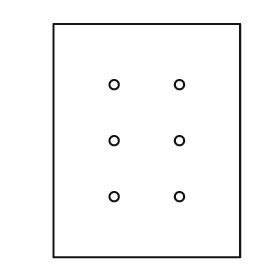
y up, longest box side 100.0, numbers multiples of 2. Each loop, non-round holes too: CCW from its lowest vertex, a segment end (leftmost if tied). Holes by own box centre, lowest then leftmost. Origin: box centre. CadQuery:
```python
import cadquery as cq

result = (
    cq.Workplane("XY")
    .moveTo(-40.0, -50.0)
    .lineTo(40.0, -50.0)
    .lineTo(40.0, 50.0)
    .lineTo(-40.0, 50.0)
    .close()
    .moveTo(-14.0, -24.0)
    .circle(2.0)
    .moveTo(14.0, -24.0)
    .circle(2.0)
    .moveTo(-14.0, 0.0)
    .circle(2.0)
    .moveTo(14.0, 0.0)
    .circle(2.0)
    .moveTo(-14.0, 24.0)
    .circle(2.0)
    .moveTo(14.0, 24.0)
    .circle(2.0)
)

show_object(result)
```